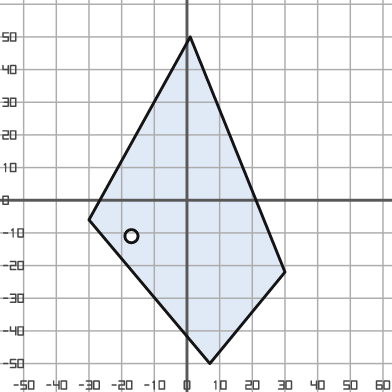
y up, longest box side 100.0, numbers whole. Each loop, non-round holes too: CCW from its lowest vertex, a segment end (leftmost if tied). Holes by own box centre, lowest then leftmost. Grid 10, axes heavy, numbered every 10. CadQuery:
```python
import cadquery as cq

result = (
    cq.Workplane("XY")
    .moveTo(7.0, -50.0)
    .lineTo(30.0, -22.0)
    .lineTo(1.0, 50.0)
    .lineTo(-30.0, -6.0)
    .close()
    .moveTo(-17.0, -11.0)
    .circle(2.0)
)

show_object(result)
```